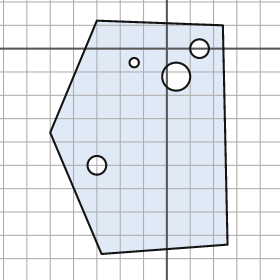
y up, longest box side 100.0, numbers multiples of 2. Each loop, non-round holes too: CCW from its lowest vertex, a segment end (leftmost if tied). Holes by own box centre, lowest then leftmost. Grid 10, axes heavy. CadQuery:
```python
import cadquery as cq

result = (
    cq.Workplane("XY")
    .moveTo(-28.0, -88.0)
    .lineTo(26.0, -84.0)
    .lineTo(24.0, 10.0)
    .lineTo(-30.0, 12.0)
    .lineTo(-50.0, -36.0)
    .close()
    .moveTo(-30.0, -50.0)
    .circle(4.0)
    .moveTo(4.0, -12.0)
    .circle(6.0)
    .moveTo(-14.0, -6.0)
    .circle(2.0)
    .moveTo(14.0, 0.0)
    .circle(4.0)
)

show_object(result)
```